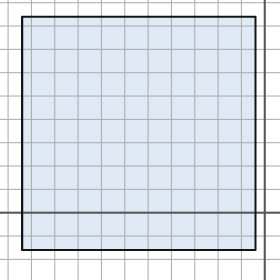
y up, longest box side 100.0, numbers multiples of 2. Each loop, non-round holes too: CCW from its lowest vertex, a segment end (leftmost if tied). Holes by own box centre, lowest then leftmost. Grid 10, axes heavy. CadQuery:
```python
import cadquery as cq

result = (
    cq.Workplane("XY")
    .moveTo(-104.0, -16.0)
    .lineTo(-4.0, -16.0)
    .lineTo(-4.0, 84.0)
    .lineTo(-104.0, 84.0)
    .close()
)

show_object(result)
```